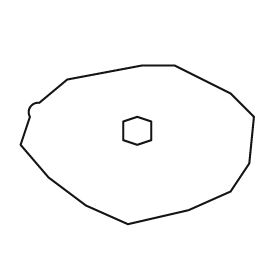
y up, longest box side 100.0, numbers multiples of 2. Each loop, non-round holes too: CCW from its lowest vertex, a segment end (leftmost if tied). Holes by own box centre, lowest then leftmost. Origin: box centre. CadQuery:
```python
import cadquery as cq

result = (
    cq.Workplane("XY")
    .moveTo(-4.0, -34.0)
    .lineTo(22.0, -28.0)
    .lineTo(40.0, -20.0)
    .lineTo(48.0, -8.0)
    .lineTo(50.0, 12.0)
    .lineTo(40.0, 22.0)
    .lineTo(16.0, 34.0)
    .lineTo(2.0, 34.0)
    .lineTo(-30.0, 28.0)
    .lineTo(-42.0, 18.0)
    .threePointArc((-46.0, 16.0), (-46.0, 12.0))
    .lineTo(-50.0, 0.0)
    .lineTo(-38.0, -14.0)
    .lineTo(-22.0, -26.0)
    .close()
    .moveTo(0.0, 0.0)
    .lineTo(6.0, 2.0)
    .lineTo(6.0, 10.0)
    .lineTo(0.0, 12.0)
    .lineTo(-6.0, 10.0)
    .lineTo(-6.0, 2.0)
    .close()
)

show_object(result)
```